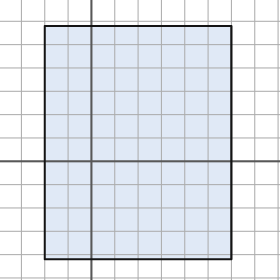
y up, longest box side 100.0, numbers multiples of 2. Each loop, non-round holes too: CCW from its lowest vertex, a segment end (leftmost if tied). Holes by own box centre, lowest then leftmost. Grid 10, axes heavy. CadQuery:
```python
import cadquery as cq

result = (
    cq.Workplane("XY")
    .moveTo(-20.0, -42.0)
    .lineTo(60.0, -42.0)
    .lineTo(60.0, 58.0)
    .lineTo(-20.0, 58.0)
    .close()
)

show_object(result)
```